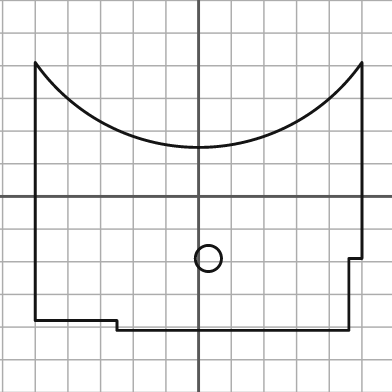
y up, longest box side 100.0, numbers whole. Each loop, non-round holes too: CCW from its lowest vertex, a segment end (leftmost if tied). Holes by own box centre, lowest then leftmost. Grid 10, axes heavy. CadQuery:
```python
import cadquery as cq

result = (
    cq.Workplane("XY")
    .moveTo(-25.0, -41.0)
    .lineTo(46.0, -41.0)
    .lineTo(46.0, -19.0)
    .lineTo(50.0, -19.0)
    .lineTo(50.0, 41.0)
    .threePointArc((0.0, 15.0), (-50.0, 41.0))
    .lineTo(-50.0, -38.0)
    .lineTo(-25.0, -38.0)
    .close()
    .moveTo(3.0, -19.0)
    .circle(4.0)
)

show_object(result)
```